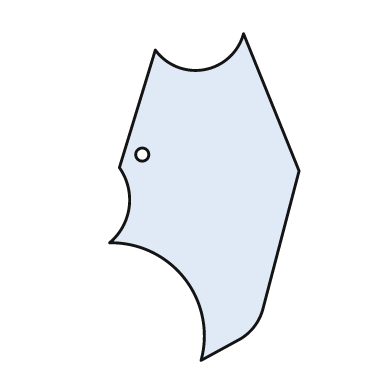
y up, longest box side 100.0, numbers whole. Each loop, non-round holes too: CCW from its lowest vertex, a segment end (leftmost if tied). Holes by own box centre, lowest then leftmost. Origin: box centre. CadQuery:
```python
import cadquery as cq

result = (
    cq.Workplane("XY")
    .moveTo(-1.0, -50.0)
    .lineTo(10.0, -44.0)
    .threePointArc((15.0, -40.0), (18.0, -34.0))
    .lineTo(29.0, 8.0)
    .lineTo(12.0, 50.0)
    .threePointArc((0.0, 39.0), (-15.0, 45.0))
    .lineTo(-26.0, 9.0)
    .threePointArc((-23.0, -3.0), (-29.0, -14.0))
    .threePointArc((-6.0, -25.0), (-1.0, -50.0))
    .close()
    .moveTo(-19.0, 13.0)
    .circle(2.0)
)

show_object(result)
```